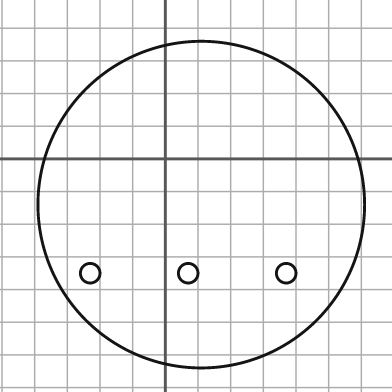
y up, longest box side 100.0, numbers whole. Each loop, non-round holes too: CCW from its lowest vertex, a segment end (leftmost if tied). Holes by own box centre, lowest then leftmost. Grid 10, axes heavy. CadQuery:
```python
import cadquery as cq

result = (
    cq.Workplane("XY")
    .moveTo(11.0, -14.0)
    .circle(50.0)
    .moveTo(-23.0, -35.0)
    .circle(3.0)
    .moveTo(7.0, -35.0)
    .circle(3.0)
    .moveTo(37.0, -35.0)
    .circle(3.0)
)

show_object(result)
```